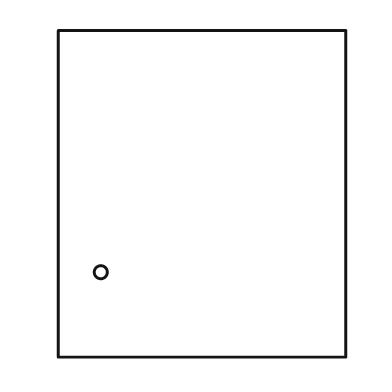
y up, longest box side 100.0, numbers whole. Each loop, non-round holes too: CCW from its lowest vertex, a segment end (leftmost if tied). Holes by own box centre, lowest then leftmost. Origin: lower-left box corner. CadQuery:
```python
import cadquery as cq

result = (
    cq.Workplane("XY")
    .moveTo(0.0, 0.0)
    .lineTo(88.0, 0.0)
    .lineTo(88.0, 100.0)
    .lineTo(0.0, 100.0)
    .close()
    .moveTo(13.0, 26.0)
    .circle(2.0)
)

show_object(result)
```